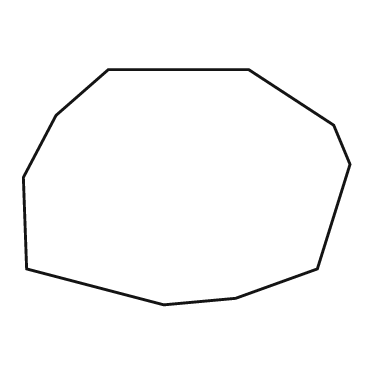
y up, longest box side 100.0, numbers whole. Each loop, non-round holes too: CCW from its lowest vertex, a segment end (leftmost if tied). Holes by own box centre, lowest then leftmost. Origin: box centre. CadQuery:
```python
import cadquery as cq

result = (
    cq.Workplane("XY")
    .moveTo(-7.0, -36.0)
    .lineTo(15.0, -34.0)
    .lineTo(40.0, -25.0)
    .lineTo(50.0, 7.0)
    .lineTo(45.0, 19.0)
    .lineTo(19.0, 36.0)
    .lineTo(-24.0, 36.0)
    .lineTo(-40.0, 22.0)
    .lineTo(-50.0, 3.0)
    .lineTo(-49.0, -25.0)
    .close()
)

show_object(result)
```